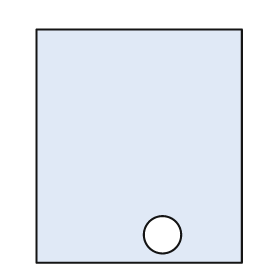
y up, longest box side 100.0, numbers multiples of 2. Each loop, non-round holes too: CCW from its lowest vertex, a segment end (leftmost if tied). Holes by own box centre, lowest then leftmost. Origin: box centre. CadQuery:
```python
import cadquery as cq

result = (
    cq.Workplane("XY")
    .moveTo(-44.0, -50.0)
    .lineTo(44.0, -50.0)
    .lineTo(44.0, 50.0)
    .lineTo(-44.0, 50.0)
    .close()
    .moveTo(10.0, -38.0)
    .circle(8.0)
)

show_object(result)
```